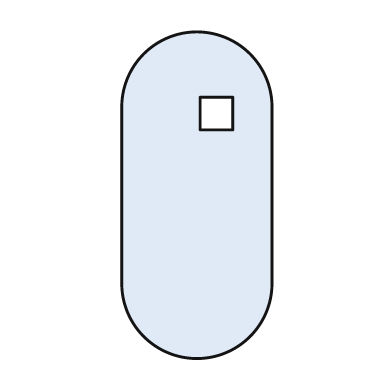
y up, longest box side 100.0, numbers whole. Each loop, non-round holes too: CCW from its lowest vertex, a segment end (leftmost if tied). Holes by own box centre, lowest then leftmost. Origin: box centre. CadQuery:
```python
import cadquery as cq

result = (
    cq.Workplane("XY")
    .moveTo(-23.0, -27.0)
    .threePointArc((0.0, -50.0), (23.0, -27.0))
    .lineTo(23.0, 27.0)
    .threePointArc((0.0, 50.0), (-23.0, 27.0))
    .close()
    .moveTo(1.0, 20.0)
    .lineTo(11.0, 20.0)
    .lineTo(11.0, 30.0)
    .lineTo(1.0, 30.0)
    .close()
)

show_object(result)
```